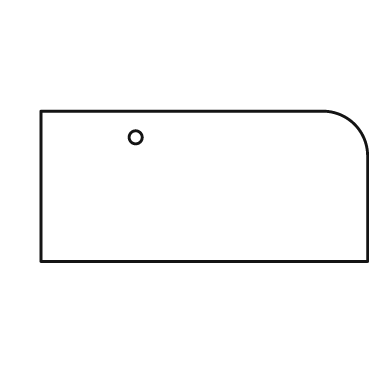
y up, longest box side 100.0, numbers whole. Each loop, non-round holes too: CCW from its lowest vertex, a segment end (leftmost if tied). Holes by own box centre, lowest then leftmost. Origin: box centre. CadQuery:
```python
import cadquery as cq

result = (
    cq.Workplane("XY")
    .moveTo(-50.0, -23.0)
    .lineTo(50.0, -23.0)
    .lineTo(50.0, 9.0)
    .threePointArc((46.0, 19.0), (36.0, 23.0))
    .lineTo(-50.0, 23.0)
    .close()
    .moveTo(-21.0, 15.0)
    .circle(2.0)
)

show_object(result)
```